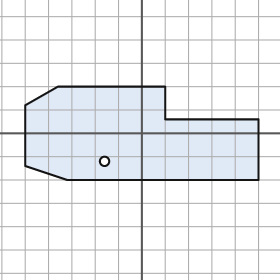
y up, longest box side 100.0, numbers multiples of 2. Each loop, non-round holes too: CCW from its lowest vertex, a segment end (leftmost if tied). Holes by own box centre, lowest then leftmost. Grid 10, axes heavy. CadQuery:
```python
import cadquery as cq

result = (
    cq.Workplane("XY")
    .moveTo(-32.0, -20.0)
    .lineTo(50.0, -20.0)
    .lineTo(50.0, 6.0)
    .lineTo(10.0, 6.0)
    .lineTo(10.0, 20.0)
    .lineTo(-36.0, 20.0)
    .lineTo(-50.0, 12.0)
    .lineTo(-50.0, -14.0)
    .close()
    .moveTo(-16.0, -12.0)
    .circle(2.0)
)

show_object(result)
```